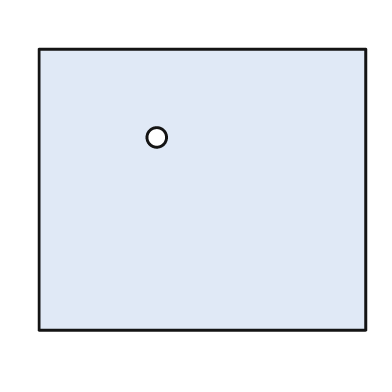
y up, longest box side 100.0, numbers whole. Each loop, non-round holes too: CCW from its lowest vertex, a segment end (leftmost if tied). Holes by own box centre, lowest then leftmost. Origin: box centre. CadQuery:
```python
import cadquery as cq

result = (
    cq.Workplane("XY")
    .moveTo(-50.0, -43.0)
    .lineTo(50.0, -43.0)
    .lineTo(50.0, 43.0)
    .lineTo(-50.0, 43.0)
    .close()
    .moveTo(-14.0, 16.0)
    .circle(3.0)
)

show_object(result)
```